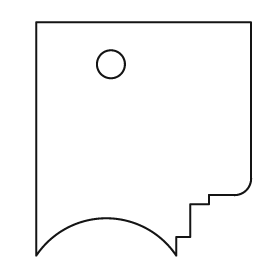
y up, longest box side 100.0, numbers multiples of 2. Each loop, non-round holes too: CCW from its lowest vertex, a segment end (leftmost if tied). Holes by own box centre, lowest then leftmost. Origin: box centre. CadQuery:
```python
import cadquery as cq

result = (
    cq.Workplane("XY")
    .moveTo(-46.0, -50.0)
    .threePointArc((-16.0, -34.0), (14.0, -50.0))
    .lineTo(14.0, -42.0)
    .lineTo(20.0, -42.0)
    .lineTo(20.0, -28.0)
    .lineTo(28.0, -28.0)
    .lineTo(28.0, -24.0)
    .lineTo(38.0, -24.0)
    .threePointArc((44.0, -22.0), (46.0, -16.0))
    .lineTo(46.0, 50.0)
    .lineTo(-46.0, 50.0)
    .close()
    .moveTo(-14.0, 32.0)
    .circle(6.0)
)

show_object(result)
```